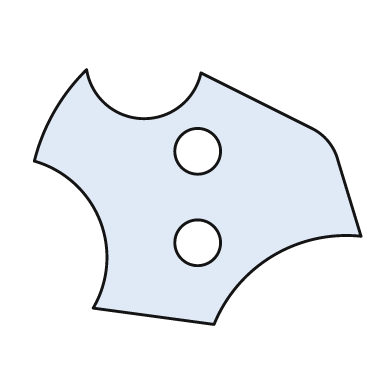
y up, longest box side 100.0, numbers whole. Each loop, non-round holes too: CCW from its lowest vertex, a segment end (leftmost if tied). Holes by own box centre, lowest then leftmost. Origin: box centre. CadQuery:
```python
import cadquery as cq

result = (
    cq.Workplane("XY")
    .moveTo(5.0, -39.0)
    .threePointArc((23.0, -18.0), (50.0, -12.0))
    .lineTo(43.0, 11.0)
    .threePointArc((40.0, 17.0), (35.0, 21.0))
    .lineTo(1.0, 38.0)
    .threePointArc((-17.0, 24.0), (-34.0, 39.0))
    .threePointArc((-44.0, 26.0), (-50.0, 11.0))
    .threePointArc((-30.0, -7.0), (-32.0, -34.0))
    .close()
    .moveTo(0.0, -14.0)
    .circle(7.0)
    .moveTo(0.0, 14.0)
    .circle(7.0)
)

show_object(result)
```